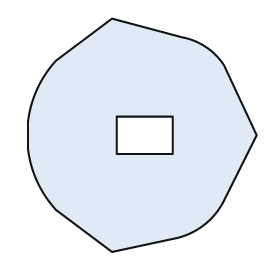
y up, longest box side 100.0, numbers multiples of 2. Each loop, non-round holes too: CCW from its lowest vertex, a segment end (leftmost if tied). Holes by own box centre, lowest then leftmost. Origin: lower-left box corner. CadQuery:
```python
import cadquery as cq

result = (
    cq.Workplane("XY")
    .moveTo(36.0, 0.0)
    .lineTo(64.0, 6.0)
    .threePointArc((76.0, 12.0), (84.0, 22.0))
    .lineTo(98.0, 50.0)
    .lineTo(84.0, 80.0)
    .threePointArc((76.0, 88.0), (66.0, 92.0))
    .lineTo(36.0, 100.0)
    .lineTo(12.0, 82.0)
    .threePointArc((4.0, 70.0), (0.0, 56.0))
    .lineTo(0.0, 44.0)
    .threePointArc((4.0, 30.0), (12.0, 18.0))
    .close()
    .moveTo(38.0, 42.0)
    .lineTo(62.0, 42.0)
    .lineTo(62.0, 58.0)
    .lineTo(38.0, 58.0)
    .close()
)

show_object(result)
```